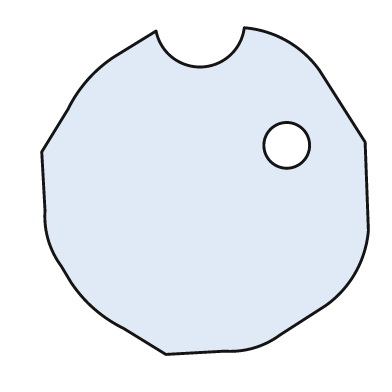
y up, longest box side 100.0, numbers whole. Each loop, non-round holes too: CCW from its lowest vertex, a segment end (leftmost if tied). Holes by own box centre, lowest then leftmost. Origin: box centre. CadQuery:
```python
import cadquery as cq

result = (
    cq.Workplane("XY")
    .moveTo(-12.0, -50.0)
    .lineTo(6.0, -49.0)
    .threePointArc((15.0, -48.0), (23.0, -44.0))
    .lineTo(37.0, -35.0)
    .threePointArc((46.0, -25.0), (50.0, -12.0))
    .lineTo(49.0, 15.0)
    .lineTo(35.0, 37.0)
    .threePointArc((25.0, 46.0), (12.0, 50.0))
    .threePointArc((-1.0, 38.0), (-15.0, 49.0))
    .lineTo(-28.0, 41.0)
    .threePointArc((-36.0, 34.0), (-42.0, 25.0))
    .lineTo(-50.0, 12.0)
    .lineTo(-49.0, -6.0)
    .threePointArc((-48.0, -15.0), (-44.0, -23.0))
    .lineTo(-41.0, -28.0)
    .threePointArc((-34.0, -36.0), (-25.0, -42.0))
    .close()
    .moveTo(25.0, 14.0)
    .circle(7.0)
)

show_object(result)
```